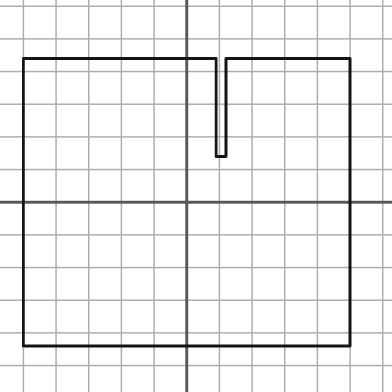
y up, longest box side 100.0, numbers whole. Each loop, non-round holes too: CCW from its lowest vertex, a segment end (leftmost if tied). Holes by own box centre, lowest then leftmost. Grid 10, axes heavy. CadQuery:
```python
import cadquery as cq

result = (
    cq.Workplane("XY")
    .moveTo(-50.0, -44.0)
    .lineTo(50.0, -44.0)
    .lineTo(50.0, 44.0)
    .lineTo(12.0, 44.0)
    .lineTo(12.0, 14.0)
    .lineTo(9.0, 14.0)
    .lineTo(9.0, 44.0)
    .lineTo(-50.0, 44.0)
    .close()
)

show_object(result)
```